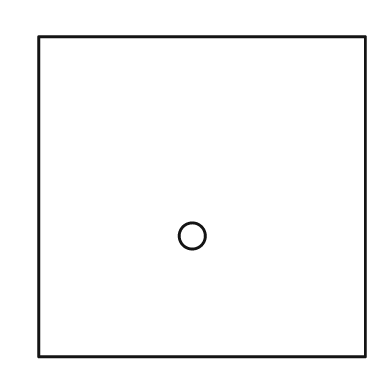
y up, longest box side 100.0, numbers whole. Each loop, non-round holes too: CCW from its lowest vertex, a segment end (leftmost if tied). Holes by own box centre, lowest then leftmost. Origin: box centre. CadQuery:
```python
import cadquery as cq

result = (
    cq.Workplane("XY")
    .moveTo(-50.0, -49.0)
    .lineTo(50.0, -49.0)
    .lineTo(50.0, 49.0)
    .lineTo(-50.0, 49.0)
    .close()
    .moveTo(-3.0, -12.0)
    .circle(4.0)
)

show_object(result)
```